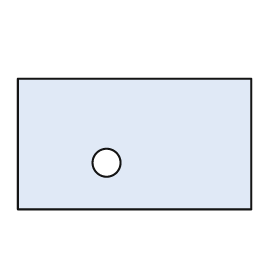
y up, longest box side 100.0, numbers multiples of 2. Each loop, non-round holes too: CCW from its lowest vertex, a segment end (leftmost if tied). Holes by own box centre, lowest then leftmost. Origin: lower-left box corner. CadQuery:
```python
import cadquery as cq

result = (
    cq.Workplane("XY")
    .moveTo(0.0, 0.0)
    .lineTo(100.0, 0.0)
    .lineTo(100.0, 56.0)
    .lineTo(0.0, 56.0)
    .close()
    .moveTo(38.0, 20.0)
    .circle(6.0)
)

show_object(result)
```